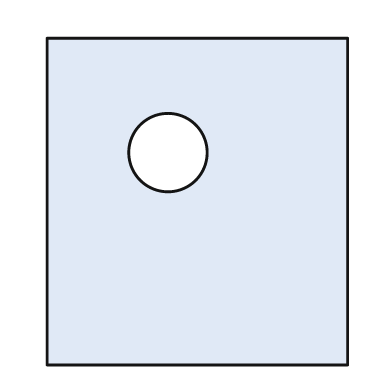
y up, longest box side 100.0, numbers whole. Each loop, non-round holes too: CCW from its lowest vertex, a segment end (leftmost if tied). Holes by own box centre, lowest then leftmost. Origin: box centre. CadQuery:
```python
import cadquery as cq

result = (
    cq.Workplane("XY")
    .moveTo(-46.0, -50.0)
    .lineTo(46.0, -50.0)
    .lineTo(46.0, 50.0)
    .lineTo(-46.0, 50.0)
    .close()
    .moveTo(-9.0, 15.0)
    .circle(12.0)
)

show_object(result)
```